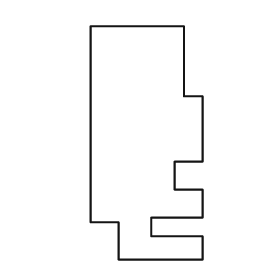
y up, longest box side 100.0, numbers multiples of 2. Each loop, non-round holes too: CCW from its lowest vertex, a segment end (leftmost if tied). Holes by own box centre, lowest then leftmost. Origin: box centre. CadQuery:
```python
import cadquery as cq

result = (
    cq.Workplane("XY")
    .moveTo(-12.0, -50.0)
    .lineTo(24.0, -50.0)
    .lineTo(24.0, -40.0)
    .lineTo(2.0, -40.0)
    .lineTo(2.0, -32.0)
    .lineTo(24.0, -32.0)
    .lineTo(24.0, -20.0)
    .lineTo(12.0, -20.0)
    .lineTo(12.0, -8.0)
    .lineTo(24.0, -8.0)
    .lineTo(24.0, 20.0)
    .lineTo(16.0, 20.0)
    .lineTo(16.0, 50.0)
    .lineTo(-24.0, 50.0)
    .lineTo(-24.0, -34.0)
    .lineTo(-12.0, -34.0)
    .close()
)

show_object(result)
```